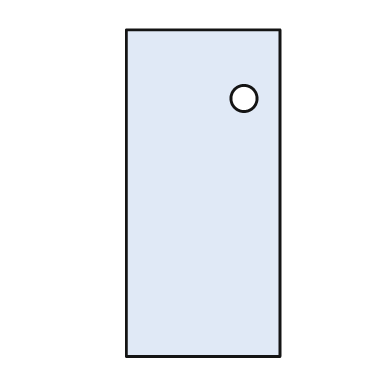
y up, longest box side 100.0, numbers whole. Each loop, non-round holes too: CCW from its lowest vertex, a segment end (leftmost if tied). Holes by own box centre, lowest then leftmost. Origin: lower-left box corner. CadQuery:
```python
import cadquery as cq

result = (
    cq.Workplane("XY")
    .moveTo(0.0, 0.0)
    .lineTo(47.0, 0.0)
    .lineTo(47.0, 100.0)
    .lineTo(0.0, 100.0)
    .close()
    .moveTo(36.0, 79.0)
    .circle(4.0)
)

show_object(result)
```